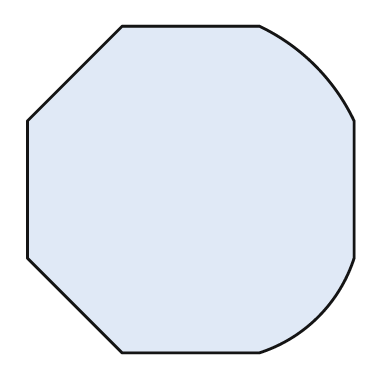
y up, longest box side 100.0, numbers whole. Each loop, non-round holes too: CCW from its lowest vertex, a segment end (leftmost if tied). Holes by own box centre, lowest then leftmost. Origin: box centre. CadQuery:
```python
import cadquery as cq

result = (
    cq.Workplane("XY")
    .moveTo(-21.0, -50.0)
    .lineTo(21.0, -50.0)
    .threePointArc((39.0, -39.0), (50.0, -21.0))
    .lineTo(50.0, 21.0)
    .threePointArc((38.0, 38.0), (21.0, 50.0))
    .lineTo(-21.0, 50.0)
    .lineTo(-50.0, 21.0)
    .lineTo(-50.0, -21.0)
    .close()
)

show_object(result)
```